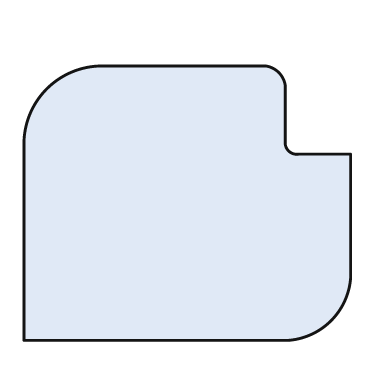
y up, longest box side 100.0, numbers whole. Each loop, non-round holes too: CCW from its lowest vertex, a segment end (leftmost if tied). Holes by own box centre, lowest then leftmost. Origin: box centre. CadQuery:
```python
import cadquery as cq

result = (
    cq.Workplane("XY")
    .moveTo(-50.0, -42.0)
    .lineTo(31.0, -42.0)
    .threePointArc((44.0, -36.0), (50.0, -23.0))
    .lineTo(50.0, 15.0)
    .lineTo(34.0, 15.0)
    .threePointArc((31.0, 16.0), (30.0, 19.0))
    .lineTo(30.0, 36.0)
    .threePointArc((28.0, 40.0), (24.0, 42.0))
    .lineTo(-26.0, 42.0)
    .threePointArc((-43.0, 35.0), (-50.0, 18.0))
    .close()
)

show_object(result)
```